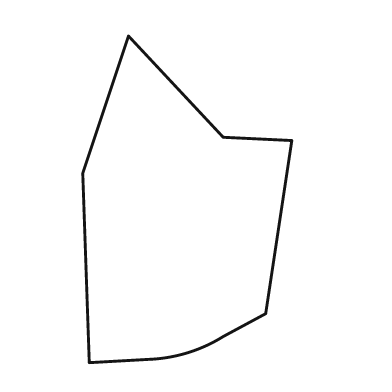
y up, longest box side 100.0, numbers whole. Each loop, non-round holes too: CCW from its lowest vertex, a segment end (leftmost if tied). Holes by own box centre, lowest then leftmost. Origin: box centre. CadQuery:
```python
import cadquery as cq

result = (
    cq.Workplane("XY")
    .moveTo(-30.0, -50.0)
    .lineTo(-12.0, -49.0)
    .threePointArc((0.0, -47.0), (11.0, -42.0))
    .lineTo(24.0, -35.0)
    .lineTo(32.0, 18.0)
    .lineTo(11.0, 19.0)
    .lineTo(-18.0, 50.0)
    .lineTo(-32.0, 8.0)
    .close()
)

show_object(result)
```